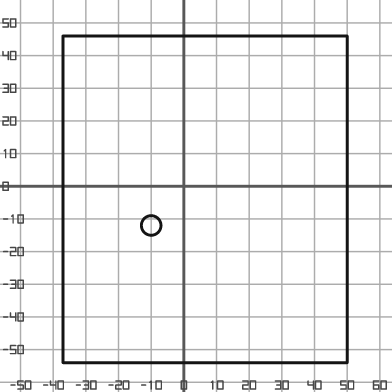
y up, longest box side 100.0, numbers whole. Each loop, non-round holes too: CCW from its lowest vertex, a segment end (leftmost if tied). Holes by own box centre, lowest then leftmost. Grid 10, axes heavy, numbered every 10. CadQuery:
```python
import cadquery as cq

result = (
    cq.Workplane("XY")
    .moveTo(-37.0, -54.0)
    .lineTo(50.0, -54.0)
    .lineTo(50.0, 46.0)
    .lineTo(-37.0, 46.0)
    .close()
    .moveTo(-10.0, -12.0)
    .circle(3.0)
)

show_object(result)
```